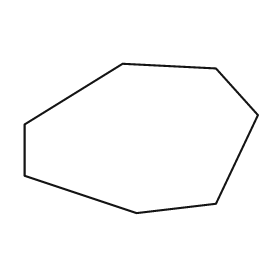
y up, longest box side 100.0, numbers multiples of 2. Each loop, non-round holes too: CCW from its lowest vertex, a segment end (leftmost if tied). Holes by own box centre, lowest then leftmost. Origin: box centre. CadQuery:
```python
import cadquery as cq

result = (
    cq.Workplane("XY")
    .moveTo(-2.0, -32.0)
    .lineTo(32.0, -28.0)
    .lineTo(50.0, 10.0)
    .lineTo(32.0, 30.0)
    .lineTo(-8.0, 32.0)
    .lineTo(-50.0, 6.0)
    .lineTo(-50.0, -16.0)
    .close()
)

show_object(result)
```